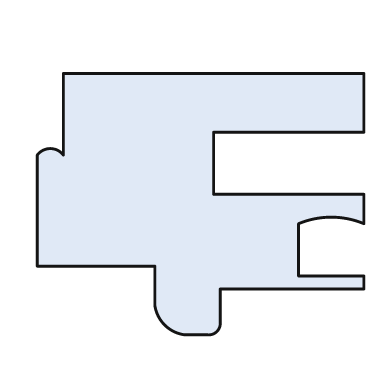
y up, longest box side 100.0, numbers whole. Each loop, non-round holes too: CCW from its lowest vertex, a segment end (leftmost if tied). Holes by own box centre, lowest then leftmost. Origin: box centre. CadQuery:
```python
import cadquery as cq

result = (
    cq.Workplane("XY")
    .moveTo(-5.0, -40.0)
    .lineTo(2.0, -40.0)
    .threePointArc((5.0, -39.0), (6.0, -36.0))
    .lineTo(6.0, -26.0)
    .lineTo(50.0, -26.0)
    .lineTo(50.0, -22.0)
    .lineTo(30.0, -22.0)
    .lineTo(30.0, -6.0)
    .threePointArc((40.0, -4.0), (50.0, -6.0))
    .lineTo(50.0, 3.0)
    .lineTo(4.0, 3.0)
    .lineTo(4.0, 22.0)
    .lineTo(50.0, 22.0)
    .lineTo(50.0, 40.0)
    .lineTo(-42.0, 40.0)
    .lineTo(-42.0, 15.0)
    .threePointArc((-46.0, 17.0), (-50.0, 15.0))
    .lineTo(-50.0, -19.0)
    .lineTo(-14.0, -19.0)
    .lineTo(-14.0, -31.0)
    .threePointArc((-11.0, -37.0), (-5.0, -40.0))
    .close()
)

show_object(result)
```